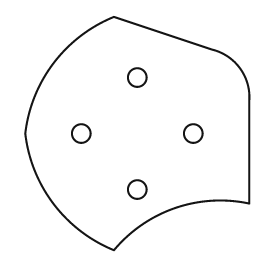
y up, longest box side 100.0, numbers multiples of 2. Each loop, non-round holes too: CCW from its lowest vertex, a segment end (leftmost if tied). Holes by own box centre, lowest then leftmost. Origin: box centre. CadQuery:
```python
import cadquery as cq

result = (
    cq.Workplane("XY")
    .moveTo(-10.0, -50.0)
    .threePointArc((16.0, -32.0), (48.0, -30.0))
    .lineTo(48.0, 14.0)
    .threePointArc((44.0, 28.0), (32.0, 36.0))
    .lineTo(-10.0, 50.0)
    .threePointArc((-36.0, 30.0), (-48.0, 0.0))
    .threePointArc((-36.0, -30.0), (-10.0, -50.0))
    .close()
    .moveTo(0.0, -24.0)
    .circle(4.0)
    .moveTo(-24.0, 0.0)
    .circle(4.0)
    .moveTo(24.0, 0.0)
    .circle(4.0)
    .moveTo(0.0, 24.0)
    .circle(4.0)
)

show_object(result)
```